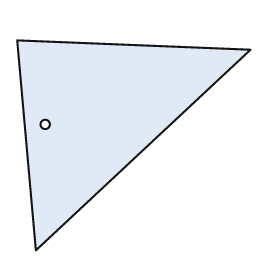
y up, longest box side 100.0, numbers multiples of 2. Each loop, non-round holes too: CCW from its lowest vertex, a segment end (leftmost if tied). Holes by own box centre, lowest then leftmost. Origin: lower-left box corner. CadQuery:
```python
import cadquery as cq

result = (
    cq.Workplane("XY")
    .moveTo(8.0, 0.0)
    .lineTo(100.0, 86.0)
    .lineTo(0.0, 90.0)
    .close()
    .moveTo(12.0, 54.0)
    .circle(2.0)
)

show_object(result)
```